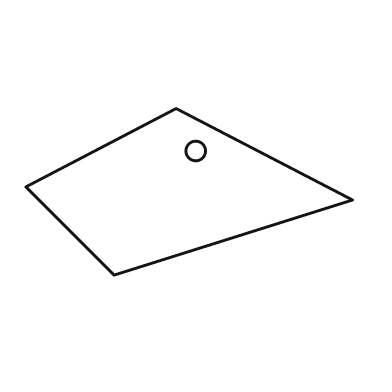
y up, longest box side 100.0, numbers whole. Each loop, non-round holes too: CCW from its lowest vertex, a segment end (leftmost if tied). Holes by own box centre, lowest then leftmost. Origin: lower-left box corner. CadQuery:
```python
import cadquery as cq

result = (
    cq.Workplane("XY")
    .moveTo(27.0, 0.0)
    .lineTo(100.0, 23.0)
    .lineTo(46.0, 51.0)
    .lineTo(0.0, 27.0)
    .close()
    .moveTo(52.0, 38.0)
    .circle(3.0)
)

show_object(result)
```